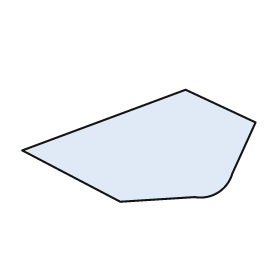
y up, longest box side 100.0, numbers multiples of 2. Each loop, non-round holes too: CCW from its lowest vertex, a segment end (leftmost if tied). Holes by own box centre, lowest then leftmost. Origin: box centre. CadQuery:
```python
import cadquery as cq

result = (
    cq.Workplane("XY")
    .moveTo(-8.0, -24.0)
    .lineTo(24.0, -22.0)
    .threePointArc((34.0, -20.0), (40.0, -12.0))
    .lineTo(50.0, 10.0)
    .lineTo(20.0, 24.0)
    .lineTo(-50.0, -2.0)
    .close()
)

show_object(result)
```